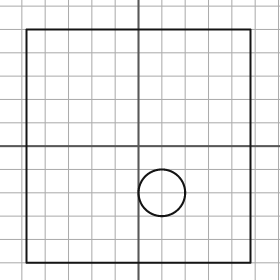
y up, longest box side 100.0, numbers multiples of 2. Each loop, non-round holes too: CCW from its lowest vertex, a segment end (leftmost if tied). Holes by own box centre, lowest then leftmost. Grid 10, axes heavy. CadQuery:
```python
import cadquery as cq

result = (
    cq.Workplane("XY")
    .moveTo(-48.0, -50.0)
    .lineTo(48.0, -50.0)
    .lineTo(48.0, 50.0)
    .lineTo(-48.0, 50.0)
    .close()
    .moveTo(10.0, -20.0)
    .circle(10.0)
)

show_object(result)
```